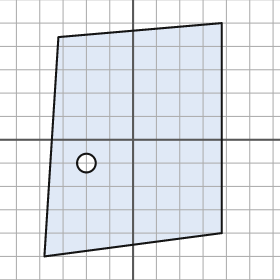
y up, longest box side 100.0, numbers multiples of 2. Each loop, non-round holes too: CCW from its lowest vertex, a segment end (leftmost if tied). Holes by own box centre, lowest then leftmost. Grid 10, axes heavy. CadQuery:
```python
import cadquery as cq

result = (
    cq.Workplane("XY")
    .moveTo(-38.0, -50.0)
    .lineTo(38.0, -40.0)
    .lineTo(38.0, 50.0)
    .lineTo(-32.0, 44.0)
    .close()
    .moveTo(-20.0, -10.0)
    .circle(4.0)
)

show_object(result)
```